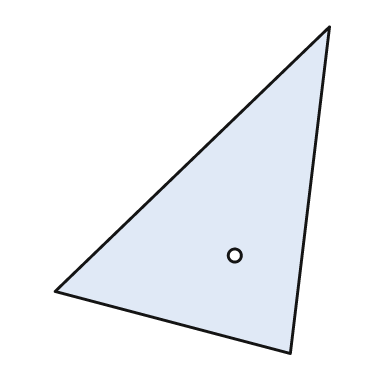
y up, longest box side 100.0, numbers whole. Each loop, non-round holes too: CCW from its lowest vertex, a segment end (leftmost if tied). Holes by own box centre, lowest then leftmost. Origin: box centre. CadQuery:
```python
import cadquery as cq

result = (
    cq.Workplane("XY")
    .moveTo(30.0, -50.0)
    .lineTo(42.0, 50.0)
    .lineTo(-42.0, -31.0)
    .close()
    .moveTo(13.0, -20.0)
    .circle(2.0)
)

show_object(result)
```